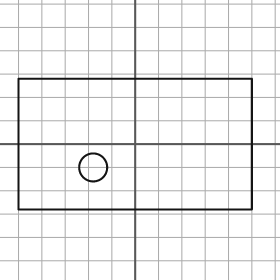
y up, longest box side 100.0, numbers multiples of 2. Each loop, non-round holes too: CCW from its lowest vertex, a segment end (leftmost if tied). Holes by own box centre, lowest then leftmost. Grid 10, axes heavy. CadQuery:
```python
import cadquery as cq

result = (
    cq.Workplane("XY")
    .moveTo(-50.0, -28.0)
    .lineTo(50.0, -28.0)
    .lineTo(50.0, 28.0)
    .lineTo(-50.0, 28.0)
    .close()
    .moveTo(-18.0, -10.0)
    .circle(6.0)
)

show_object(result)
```